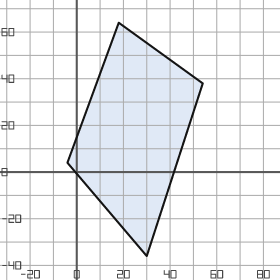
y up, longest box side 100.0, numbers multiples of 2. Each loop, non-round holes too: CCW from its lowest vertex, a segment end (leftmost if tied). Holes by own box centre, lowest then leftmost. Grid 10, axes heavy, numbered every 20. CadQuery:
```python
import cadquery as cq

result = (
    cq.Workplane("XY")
    .moveTo(30.0, -36.0)
    .lineTo(54.0, 38.0)
    .lineTo(18.0, 64.0)
    .lineTo(-4.0, 4.0)
    .close()
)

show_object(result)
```